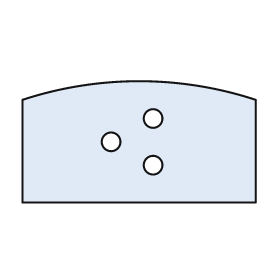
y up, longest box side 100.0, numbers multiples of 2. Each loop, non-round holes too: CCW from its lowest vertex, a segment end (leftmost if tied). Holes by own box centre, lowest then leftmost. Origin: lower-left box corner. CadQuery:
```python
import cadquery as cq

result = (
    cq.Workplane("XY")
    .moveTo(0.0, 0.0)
    .lineTo(100.0, 0.0)
    .lineTo(100.0, 44.0)
    .threePointArc((50.0, 52.0), (0.0, 44.0))
    .close()
    .moveTo(56.0, 16.0)
    .circle(4.0)
    .moveTo(38.0, 26.0)
    .circle(4.0)
    .moveTo(56.0, 36.0)
    .circle(4.0)
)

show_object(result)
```